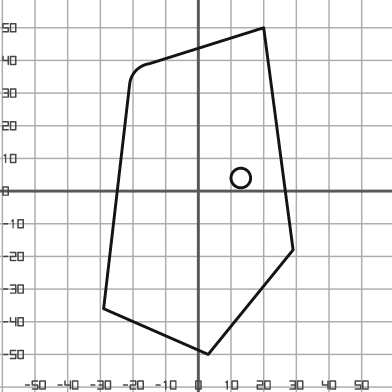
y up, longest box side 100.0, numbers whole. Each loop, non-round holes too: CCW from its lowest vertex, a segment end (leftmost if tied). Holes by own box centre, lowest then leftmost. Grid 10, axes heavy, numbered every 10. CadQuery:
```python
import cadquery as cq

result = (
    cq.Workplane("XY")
    .moveTo(3.0, -50.0)
    .lineTo(29.0, -18.0)
    .lineTo(20.0, 50.0)
    .lineTo(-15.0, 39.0)
    .threePointArc((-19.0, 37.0), (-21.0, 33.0))
    .lineTo(-29.0, -36.0)
    .close()
    .moveTo(13.0, 4.0)
    .circle(3.0)
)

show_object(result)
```